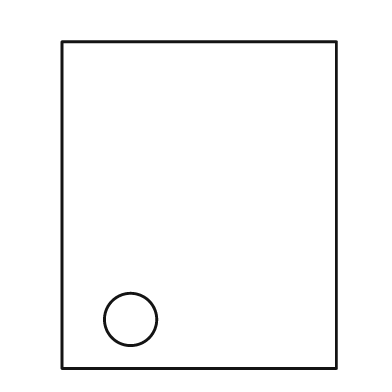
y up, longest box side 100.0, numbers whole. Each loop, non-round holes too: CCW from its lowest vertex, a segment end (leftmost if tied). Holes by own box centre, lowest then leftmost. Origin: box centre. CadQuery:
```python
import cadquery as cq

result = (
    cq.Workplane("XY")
    .moveTo(-42.0, -50.0)
    .lineTo(42.0, -50.0)
    .lineTo(42.0, 50.0)
    .lineTo(-42.0, 50.0)
    .close()
    .moveTo(-21.0, -35.0)
    .circle(8.0)
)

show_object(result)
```